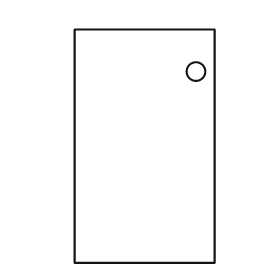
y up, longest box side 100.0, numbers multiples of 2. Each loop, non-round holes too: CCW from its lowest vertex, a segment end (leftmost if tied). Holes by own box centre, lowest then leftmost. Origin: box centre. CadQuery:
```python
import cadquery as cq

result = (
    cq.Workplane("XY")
    .moveTo(-30.0, -50.0)
    .lineTo(30.0, -50.0)
    .lineTo(30.0, 50.0)
    .lineTo(-30.0, 50.0)
    .close()
    .moveTo(22.0, 32.0)
    .circle(4.0)
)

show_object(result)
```